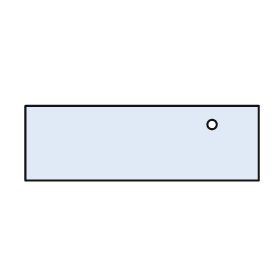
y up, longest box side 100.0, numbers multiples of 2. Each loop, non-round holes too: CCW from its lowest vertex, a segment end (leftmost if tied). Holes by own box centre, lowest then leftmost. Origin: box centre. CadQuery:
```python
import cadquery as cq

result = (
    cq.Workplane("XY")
    .moveTo(-50.0, -16.0)
    .lineTo(50.0, -16.0)
    .lineTo(50.0, 16.0)
    .lineTo(-50.0, 16.0)
    .close()
    .moveTo(30.0, 8.0)
    .circle(2.0)
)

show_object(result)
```